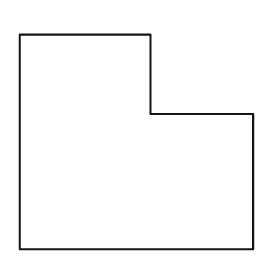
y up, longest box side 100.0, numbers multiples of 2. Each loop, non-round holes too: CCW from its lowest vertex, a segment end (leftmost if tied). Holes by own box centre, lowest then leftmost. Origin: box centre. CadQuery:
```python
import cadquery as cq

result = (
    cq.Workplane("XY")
    .moveTo(-50.0, -46.0)
    .lineTo(50.0, -46.0)
    .lineTo(50.0, 12.0)
    .lineTo(6.0, 12.0)
    .lineTo(6.0, 46.0)
    .lineTo(-50.0, 46.0)
    .close()
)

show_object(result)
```